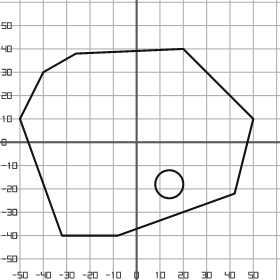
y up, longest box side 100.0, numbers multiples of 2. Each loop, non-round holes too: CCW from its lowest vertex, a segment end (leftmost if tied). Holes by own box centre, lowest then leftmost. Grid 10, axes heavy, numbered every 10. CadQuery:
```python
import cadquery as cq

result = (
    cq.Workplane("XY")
    .moveTo(-32.0, -40.0)
    .lineTo(-8.0, -40.0)
    .lineTo(42.0, -22.0)
    .lineTo(50.0, 10.0)
    .lineTo(20.0, 40.0)
    .lineTo(-26.0, 38.0)
    .lineTo(-40.0, 30.0)
    .lineTo(-50.0, 10.0)
    .close()
    .moveTo(14.0, -18.0)
    .circle(6.0)
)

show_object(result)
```